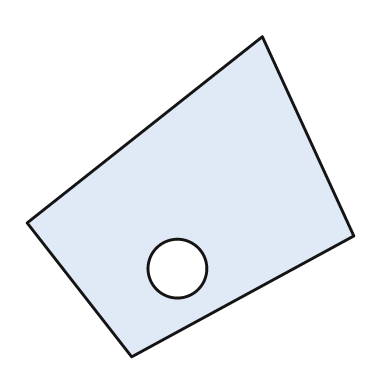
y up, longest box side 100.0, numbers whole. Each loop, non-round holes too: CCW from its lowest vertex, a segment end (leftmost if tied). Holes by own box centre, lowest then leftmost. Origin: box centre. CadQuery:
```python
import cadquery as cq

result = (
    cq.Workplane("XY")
    .moveTo(-18.0, -49.0)
    .lineTo(50.0, -12.0)
    .lineTo(22.0, 49.0)
    .lineTo(-50.0, -8.0)
    .close()
    .moveTo(-4.0, -22.0)
    .circle(9.0)
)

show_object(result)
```